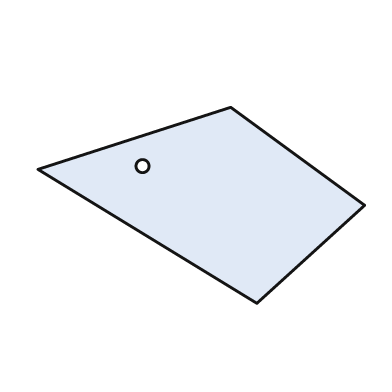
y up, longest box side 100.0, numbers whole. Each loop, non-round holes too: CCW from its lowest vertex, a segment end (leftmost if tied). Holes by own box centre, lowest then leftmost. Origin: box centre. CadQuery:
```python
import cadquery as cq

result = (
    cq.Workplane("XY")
    .moveTo(17.0, -30.0)
    .lineTo(50.0, 0.0)
    .lineTo(9.0, 30.0)
    .lineTo(-50.0, 11.0)
    .close()
    .moveTo(-18.0, 12.0)
    .circle(2.0)
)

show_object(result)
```